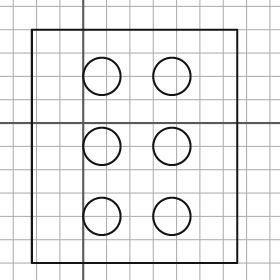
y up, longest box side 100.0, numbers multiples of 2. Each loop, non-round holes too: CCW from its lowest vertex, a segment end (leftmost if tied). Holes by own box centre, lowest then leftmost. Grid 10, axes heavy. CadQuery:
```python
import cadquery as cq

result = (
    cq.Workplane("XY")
    .moveTo(-22.0, -60.0)
    .lineTo(66.0, -60.0)
    .lineTo(66.0, 40.0)
    .lineTo(-22.0, 40.0)
    .close()
    .moveTo(8.0, -40.0)
    .circle(8.0)
    .moveTo(38.0, -40.0)
    .circle(8.0)
    .moveTo(8.0, -10.0)
    .circle(8.0)
    .moveTo(38.0, -10.0)
    .circle(8.0)
    .moveTo(8.0, 20.0)
    .circle(8.0)
    .moveTo(38.0, 20.0)
    .circle(8.0)
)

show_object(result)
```